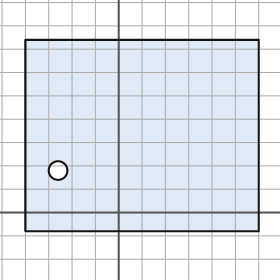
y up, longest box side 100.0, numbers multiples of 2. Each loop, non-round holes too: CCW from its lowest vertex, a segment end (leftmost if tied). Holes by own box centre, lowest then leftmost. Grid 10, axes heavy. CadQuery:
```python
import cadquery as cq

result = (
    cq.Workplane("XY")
    .moveTo(-40.0, -8.0)
    .lineTo(60.0, -8.0)
    .lineTo(60.0, 74.0)
    .lineTo(-40.0, 74.0)
    .close()
    .moveTo(-26.0, 18.0)
    .circle(4.0)
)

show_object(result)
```